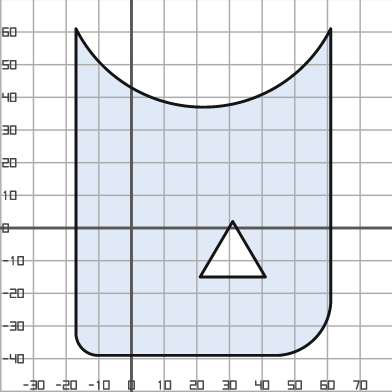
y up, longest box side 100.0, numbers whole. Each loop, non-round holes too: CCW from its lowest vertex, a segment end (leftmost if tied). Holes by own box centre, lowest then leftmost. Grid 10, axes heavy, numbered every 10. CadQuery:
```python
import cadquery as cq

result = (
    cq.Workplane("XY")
    .moveTo(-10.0, -39.0)
    .lineTo(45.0, -39.0)
    .threePointArc((56.0, -34.0), (61.0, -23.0))
    .lineTo(61.0, 61.0)
    .threePointArc((22.0, 37.0), (-17.0, 61.0))
    .lineTo(-17.0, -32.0)
    .threePointArc((-15.0, -37.0), (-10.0, -39.0))
    .close()
    .moveTo(21.0, -15.0)
    .lineTo(41.0, -15.0)
    .lineTo(31.0, 2.0)
    .close()
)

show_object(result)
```